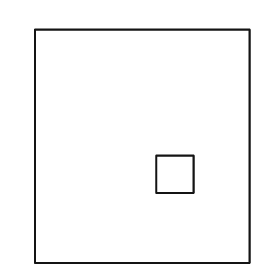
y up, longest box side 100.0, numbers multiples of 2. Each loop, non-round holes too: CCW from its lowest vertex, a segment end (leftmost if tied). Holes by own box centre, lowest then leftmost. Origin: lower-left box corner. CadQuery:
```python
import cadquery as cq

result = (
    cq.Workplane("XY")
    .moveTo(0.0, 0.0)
    .lineTo(92.0, 0.0)
    .lineTo(92.0, 100.0)
    .lineTo(0.0, 100.0)
    .close()
    .moveTo(52.0, 30.0)
    .lineTo(68.0, 30.0)
    .lineTo(68.0, 46.0)
    .lineTo(52.0, 46.0)
    .close()
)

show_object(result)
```